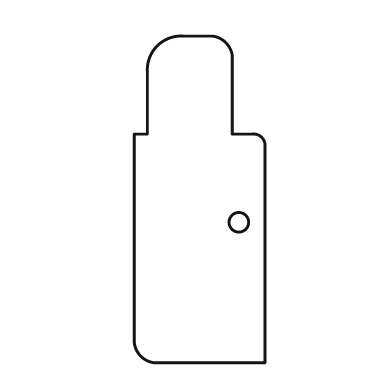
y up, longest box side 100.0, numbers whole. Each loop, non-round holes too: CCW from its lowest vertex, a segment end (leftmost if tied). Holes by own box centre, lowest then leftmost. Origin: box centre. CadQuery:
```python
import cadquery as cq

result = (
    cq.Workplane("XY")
    .moveTo(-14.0, -50.0)
    .lineTo(20.0, -50.0)
    .lineTo(20.0, 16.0)
    .threePointArc((19.0, 19.0), (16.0, 20.0))
    .lineTo(10.0, 20.0)
    .lineTo(10.0, 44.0)
    .threePointArc((8.0, 48.0), (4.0, 50.0))
    .lineTo(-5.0, 50.0)
    .threePointArc((-13.0, 47.0), (-16.0, 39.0))
    .lineTo(-16.0, 20.0)
    .lineTo(-20.0, 20.0)
    .lineTo(-20.0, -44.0)
    .threePointArc((-18.0, -48.0), (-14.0, -50.0))
    .close()
    .moveTo(12.0, -7.0)
    .circle(3.0)
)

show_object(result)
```